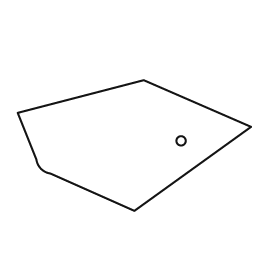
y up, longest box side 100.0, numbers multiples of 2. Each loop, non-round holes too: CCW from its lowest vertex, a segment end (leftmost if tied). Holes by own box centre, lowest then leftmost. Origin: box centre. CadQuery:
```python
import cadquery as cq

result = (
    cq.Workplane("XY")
    .moveTo(0.0, -28.0)
    .lineTo(50.0, 8.0)
    .lineTo(4.0, 28.0)
    .lineTo(-50.0, 14.0)
    .lineTo(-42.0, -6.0)
    .threePointArc((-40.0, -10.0), (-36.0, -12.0))
    .close()
    .moveTo(20.0, 2.0)
    .circle(2.0)
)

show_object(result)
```